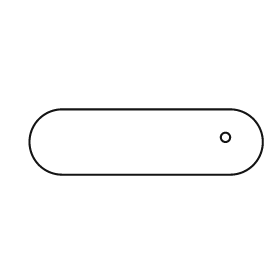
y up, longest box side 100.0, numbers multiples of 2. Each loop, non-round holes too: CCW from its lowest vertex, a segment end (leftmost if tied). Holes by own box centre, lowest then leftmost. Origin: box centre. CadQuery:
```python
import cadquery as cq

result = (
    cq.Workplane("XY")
    .moveTo(-36.0, -14.0)
    .lineTo(36.0, -14.0)
    .threePointArc((50.0, 0.0), (36.0, 14.0))
    .lineTo(-36.0, 14.0)
    .threePointArc((-50.0, 0.0), (-36.0, -14.0))
    .close()
    .moveTo(34.0, 2.0)
    .circle(2.0)
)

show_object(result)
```